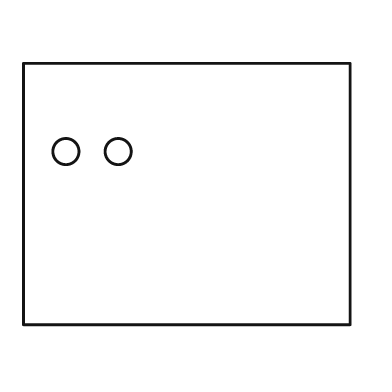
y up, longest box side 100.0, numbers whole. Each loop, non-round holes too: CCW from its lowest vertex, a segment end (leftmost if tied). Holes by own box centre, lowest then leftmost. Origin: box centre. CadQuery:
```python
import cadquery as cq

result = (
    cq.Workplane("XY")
    .moveTo(-50.0, -40.0)
    .lineTo(50.0, -40.0)
    .lineTo(50.0, 40.0)
    .lineTo(-50.0, 40.0)
    .close()
    .moveTo(-37.0, 13.0)
    .circle(4.0)
    .moveTo(-21.0, 13.0)
    .circle(4.0)
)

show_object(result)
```